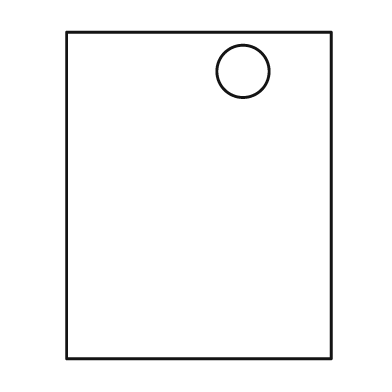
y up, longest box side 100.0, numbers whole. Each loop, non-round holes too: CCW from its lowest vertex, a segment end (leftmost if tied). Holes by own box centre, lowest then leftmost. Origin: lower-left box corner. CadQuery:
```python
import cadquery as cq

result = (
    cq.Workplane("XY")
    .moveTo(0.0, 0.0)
    .lineTo(81.0, 0.0)
    .lineTo(81.0, 100.0)
    .lineTo(0.0, 100.0)
    .close()
    .moveTo(54.0, 88.0)
    .circle(8.0)
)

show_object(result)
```